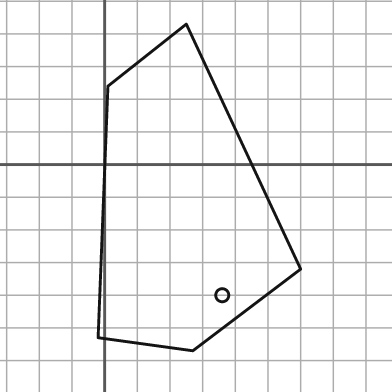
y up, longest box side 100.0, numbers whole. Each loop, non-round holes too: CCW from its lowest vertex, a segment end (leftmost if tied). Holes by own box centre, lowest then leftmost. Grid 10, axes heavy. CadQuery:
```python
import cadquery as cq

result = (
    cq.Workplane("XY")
    .moveTo(27.0, -57.0)
    .lineTo(60.0, -32.0)
    .lineTo(25.0, 43.0)
    .lineTo(1.0, 24.0)
    .lineTo(-2.0, -53.0)
    .close()
    .moveTo(36.0, -40.0)
    .circle(2.0)
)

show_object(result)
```